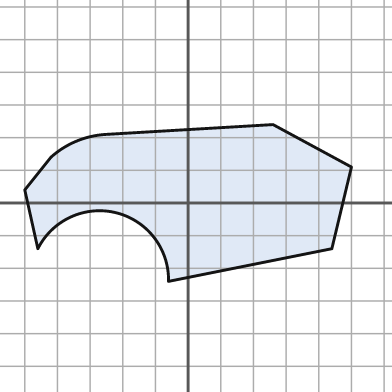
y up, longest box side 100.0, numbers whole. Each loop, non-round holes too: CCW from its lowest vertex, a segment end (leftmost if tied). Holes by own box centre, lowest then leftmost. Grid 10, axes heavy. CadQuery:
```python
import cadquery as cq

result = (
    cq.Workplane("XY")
    .moveTo(-6.0, -24.0)
    .lineTo(44.0, -14.0)
    .lineTo(50.0, 11.0)
    .lineTo(26.0, 24.0)
    .lineTo(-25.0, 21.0)
    .threePointArc((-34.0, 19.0), (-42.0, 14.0))
    .lineTo(-50.0, 4.0)
    .lineTo(-46.0, -14.0)
    .threePointArc((-22.0, -3.0), (-6.0, -24.0))
    .close()
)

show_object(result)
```